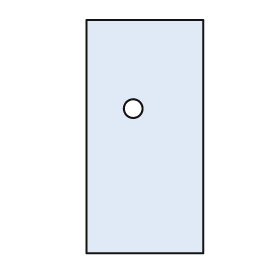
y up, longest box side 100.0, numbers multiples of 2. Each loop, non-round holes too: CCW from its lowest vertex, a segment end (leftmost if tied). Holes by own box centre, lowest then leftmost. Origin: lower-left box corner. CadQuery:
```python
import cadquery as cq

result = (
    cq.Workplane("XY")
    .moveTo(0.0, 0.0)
    .lineTo(50.0, 0.0)
    .lineTo(50.0, 100.0)
    .lineTo(0.0, 100.0)
    .close()
    .moveTo(20.0, 62.0)
    .circle(4.0)
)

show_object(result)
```